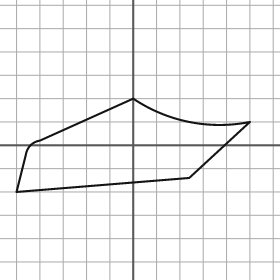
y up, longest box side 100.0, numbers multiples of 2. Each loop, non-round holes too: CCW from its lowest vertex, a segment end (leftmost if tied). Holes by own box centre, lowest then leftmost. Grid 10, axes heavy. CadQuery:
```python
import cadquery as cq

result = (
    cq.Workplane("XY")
    .moveTo(-50.0, -20.0)
    .lineTo(24.0, -14.0)
    .lineTo(50.0, 10.0)
    .threePointArc((24.0, 10.0), (0.0, 20.0))
    .lineTo(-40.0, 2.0)
    .threePointArc((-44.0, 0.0), (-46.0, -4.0))
    .close()
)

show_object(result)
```